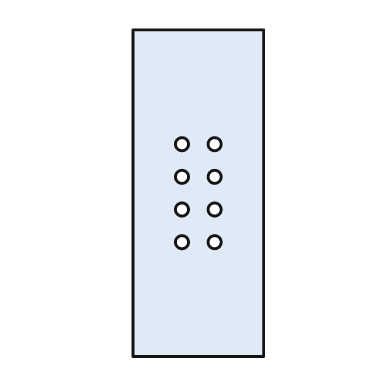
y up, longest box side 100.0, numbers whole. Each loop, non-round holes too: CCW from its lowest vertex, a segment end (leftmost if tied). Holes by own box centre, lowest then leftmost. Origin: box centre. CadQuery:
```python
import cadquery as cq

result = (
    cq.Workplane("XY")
    .moveTo(-20.0, -50.0)
    .lineTo(20.0, -50.0)
    .lineTo(20.0, 50.0)
    .lineTo(-20.0, 50.0)
    .close()
    .moveTo(-5.0, -15.0)
    .circle(2.0)
    .moveTo(5.0, -15.0)
    .circle(2.0)
    .moveTo(-5.0, -5.0)
    .circle(2.0)
    .moveTo(5.0, -5.0)
    .circle(2.0)
    .moveTo(-5.0, 5.0)
    .circle(2.0)
    .moveTo(5.0, 5.0)
    .circle(2.0)
    .moveTo(-5.0, 15.0)
    .circle(2.0)
    .moveTo(5.0, 15.0)
    .circle(2.0)
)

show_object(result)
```